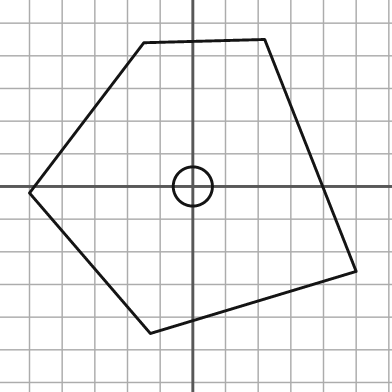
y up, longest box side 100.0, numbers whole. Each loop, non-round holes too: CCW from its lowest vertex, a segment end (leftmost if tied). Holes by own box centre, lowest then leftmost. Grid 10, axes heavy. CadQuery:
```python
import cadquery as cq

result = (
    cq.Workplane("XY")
    .moveTo(-13.0, -45.0)
    .lineTo(50.0, -26.0)
    .lineTo(22.0, 45.0)
    .lineTo(-15.0, 44.0)
    .lineTo(-50.0, -2.0)
    .close()
    .moveTo(0.0, 0.0)
    .circle(6.0)
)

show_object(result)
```